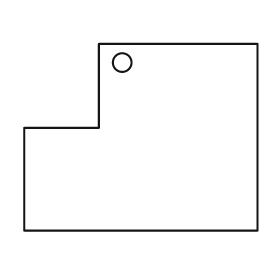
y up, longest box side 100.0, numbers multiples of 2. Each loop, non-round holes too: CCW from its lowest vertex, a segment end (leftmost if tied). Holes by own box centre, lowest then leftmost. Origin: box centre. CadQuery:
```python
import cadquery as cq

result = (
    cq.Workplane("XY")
    .moveTo(-50.0, -40.0)
    .lineTo(50.0, -40.0)
    .lineTo(50.0, 40.0)
    .lineTo(-18.0, 40.0)
    .lineTo(-18.0, 4.0)
    .lineTo(-50.0, 4.0)
    .close()
    .moveTo(-8.0, 32.0)
    .circle(4.0)
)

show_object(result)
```